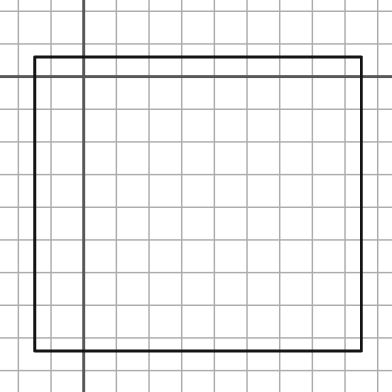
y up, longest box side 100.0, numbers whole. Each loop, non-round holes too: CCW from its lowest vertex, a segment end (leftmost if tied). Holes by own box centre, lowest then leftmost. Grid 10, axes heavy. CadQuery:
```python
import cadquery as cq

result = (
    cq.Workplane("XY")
    .moveTo(-15.0, -84.0)
    .lineTo(85.0, -84.0)
    .lineTo(85.0, 6.0)
    .lineTo(-15.0, 6.0)
    .close()
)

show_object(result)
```